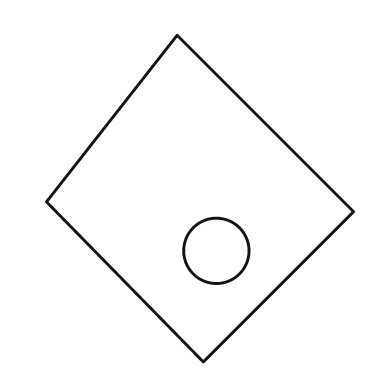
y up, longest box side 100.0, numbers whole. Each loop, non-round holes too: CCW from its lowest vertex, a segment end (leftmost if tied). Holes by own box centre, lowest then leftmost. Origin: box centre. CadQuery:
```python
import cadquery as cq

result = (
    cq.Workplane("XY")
    .moveTo(1.0, -50.0)
    .lineTo(47.0, -4.0)
    .lineTo(-7.0, 50.0)
    .lineTo(-47.0, -1.0)
    .close()
    .moveTo(5.0, -16.0)
    .circle(10.0)
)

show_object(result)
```